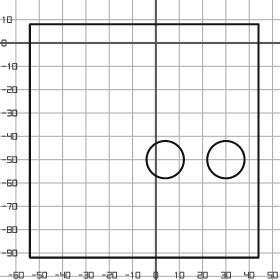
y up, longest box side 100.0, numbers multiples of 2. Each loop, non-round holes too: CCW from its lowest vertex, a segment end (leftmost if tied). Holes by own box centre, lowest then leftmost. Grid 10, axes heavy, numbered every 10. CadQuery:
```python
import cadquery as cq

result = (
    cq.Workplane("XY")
    .moveTo(-54.0, -92.0)
    .lineTo(44.0, -92.0)
    .lineTo(44.0, 8.0)
    .lineTo(-54.0, 8.0)
    .close()
    .moveTo(4.0, -50.0)
    .circle(8.0)
    .moveTo(30.0, -50.0)
    .circle(8.0)
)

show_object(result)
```